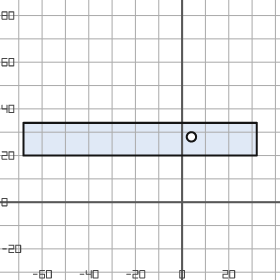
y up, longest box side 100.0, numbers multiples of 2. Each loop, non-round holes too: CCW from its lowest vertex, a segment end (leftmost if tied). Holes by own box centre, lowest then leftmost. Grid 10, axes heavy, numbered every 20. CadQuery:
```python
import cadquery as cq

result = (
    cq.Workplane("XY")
    .moveTo(-68.0, 20.0)
    .lineTo(32.0, 20.0)
    .lineTo(32.0, 34.0)
    .lineTo(-68.0, 34.0)
    .close()
    .moveTo(4.0, 28.0)
    .circle(2.0)
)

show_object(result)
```